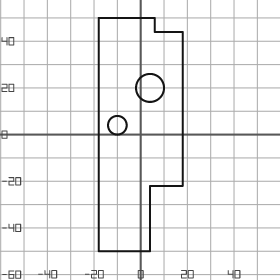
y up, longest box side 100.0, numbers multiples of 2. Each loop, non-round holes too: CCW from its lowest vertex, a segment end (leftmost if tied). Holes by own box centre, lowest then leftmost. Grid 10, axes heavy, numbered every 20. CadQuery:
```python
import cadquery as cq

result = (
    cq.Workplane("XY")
    .moveTo(-18.0, -50.0)
    .lineTo(4.0, -50.0)
    .lineTo(4.0, -22.0)
    .lineTo(18.0, -22.0)
    .lineTo(18.0, 44.0)
    .lineTo(6.0, 44.0)
    .lineTo(6.0, 50.0)
    .lineTo(-18.0, 50.0)
    .close()
    .moveTo(-10.0, 4.0)
    .circle(4.0)
    .moveTo(4.0, 20.0)
    .circle(6.0)
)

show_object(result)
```